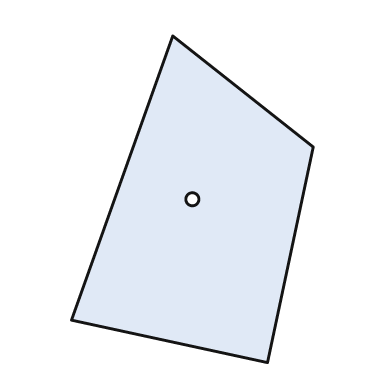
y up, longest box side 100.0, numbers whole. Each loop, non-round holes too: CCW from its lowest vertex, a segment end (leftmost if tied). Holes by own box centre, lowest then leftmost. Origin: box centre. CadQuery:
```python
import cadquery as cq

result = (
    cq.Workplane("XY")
    .moveTo(23.0, -50.0)
    .lineTo(37.0, 16.0)
    .lineTo(-6.0, 50.0)
    .lineTo(-37.0, -37.0)
    .close()
    .moveTo(0.0, 0.0)
    .circle(2.0)
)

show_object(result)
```